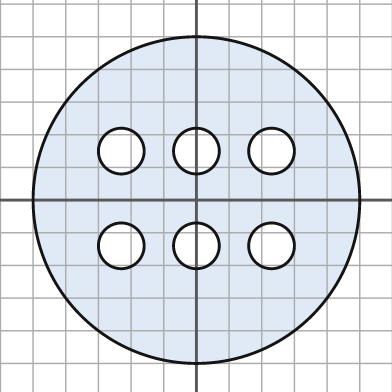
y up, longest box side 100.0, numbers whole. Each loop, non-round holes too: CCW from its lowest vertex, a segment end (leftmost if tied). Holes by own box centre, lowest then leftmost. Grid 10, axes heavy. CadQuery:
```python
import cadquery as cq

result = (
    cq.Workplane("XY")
    .moveTo(0.0, 0.0)
    .circle(50.0)
    .moveTo(-23.0, -14.0)
    .circle(7.0)
    .moveTo(0.0, -14.0)
    .circle(7.0)
    .moveTo(23.0, -14.0)
    .circle(7.0)
    .moveTo(-23.0, 15.0)
    .circle(7.0)
    .moveTo(0.0, 15.0)
    .circle(7.0)
    .moveTo(23.0, 15.0)
    .circle(7.0)
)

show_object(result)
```